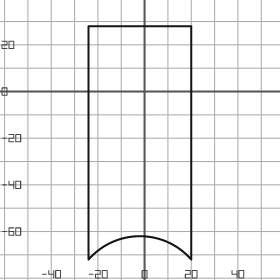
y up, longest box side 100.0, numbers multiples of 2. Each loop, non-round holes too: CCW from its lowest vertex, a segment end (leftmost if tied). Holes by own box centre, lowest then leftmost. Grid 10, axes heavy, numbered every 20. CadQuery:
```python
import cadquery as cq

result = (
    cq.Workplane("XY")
    .moveTo(-24.0, -72.0)
    .threePointArc((-2.0, -62.0), (20.0, -72.0))
    .lineTo(20.0, 28.0)
    .lineTo(-24.0, 28.0)
    .close()
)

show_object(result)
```